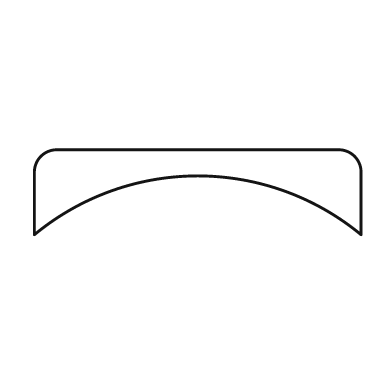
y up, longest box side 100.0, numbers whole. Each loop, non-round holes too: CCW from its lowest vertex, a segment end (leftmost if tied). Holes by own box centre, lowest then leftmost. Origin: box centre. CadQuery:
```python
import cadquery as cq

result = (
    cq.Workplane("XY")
    .moveTo(-50.0, -13.0)
    .threePointArc((0.0, 5.0), (50.0, -13.0))
    .lineTo(50.0, 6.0)
    .threePointArc((48.0, 11.0), (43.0, 13.0))
    .lineTo(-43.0, 13.0)
    .threePointArc((-48.0, 11.0), (-50.0, 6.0))
    .close()
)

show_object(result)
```